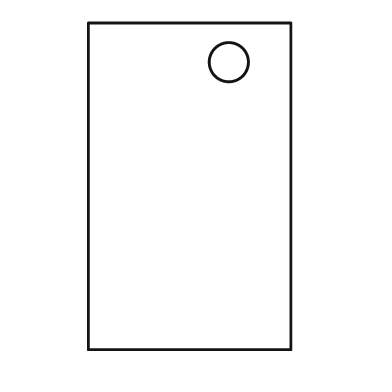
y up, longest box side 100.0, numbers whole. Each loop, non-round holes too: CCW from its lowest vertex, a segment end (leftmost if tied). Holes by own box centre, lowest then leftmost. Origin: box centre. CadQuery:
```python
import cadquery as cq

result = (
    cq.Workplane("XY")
    .moveTo(-31.0, -50.0)
    .lineTo(31.0, -50.0)
    .lineTo(31.0, 50.0)
    .lineTo(-31.0, 50.0)
    .close()
    .moveTo(12.0, 38.0)
    .circle(6.0)
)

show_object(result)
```